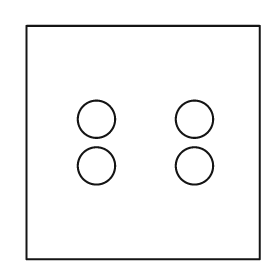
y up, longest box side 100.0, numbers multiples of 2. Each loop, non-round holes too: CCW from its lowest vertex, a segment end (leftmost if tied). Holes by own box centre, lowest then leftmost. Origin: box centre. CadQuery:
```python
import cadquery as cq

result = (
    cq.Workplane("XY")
    .moveTo(-50.0, -50.0)
    .lineTo(50.0, -50.0)
    .lineTo(50.0, 50.0)
    .lineTo(-50.0, 50.0)
    .close()
    .moveTo(-20.0, -10.0)
    .circle(8.0)
    .moveTo(22.0, -10.0)
    .circle(8.0)
    .moveTo(-20.0, 10.0)
    .circle(8.0)
    .moveTo(22.0, 10.0)
    .circle(8.0)
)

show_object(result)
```